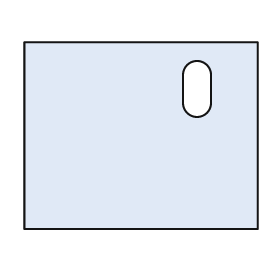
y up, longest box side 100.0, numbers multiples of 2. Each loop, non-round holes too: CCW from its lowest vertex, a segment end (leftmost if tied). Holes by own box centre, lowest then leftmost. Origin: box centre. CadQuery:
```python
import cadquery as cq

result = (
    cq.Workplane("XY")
    .moveTo(-50.0, -40.0)
    .lineTo(50.0, -40.0)
    .lineTo(50.0, 40.0)
    .lineTo(-50.0, 40.0)
    .close()
    .moveTo(18.0, 14.0)
    .threePointArc((24.0, 8.0), (30.0, 14.0))
    .lineTo(30.0, 26.0)
    .threePointArc((24.0, 32.0), (18.0, 26.0))
    .close()
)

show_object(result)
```